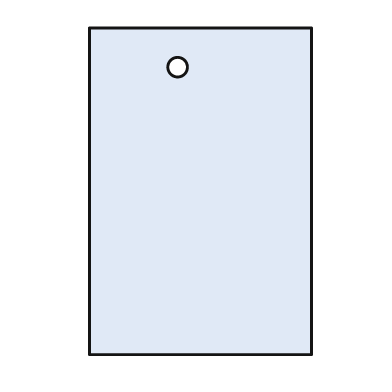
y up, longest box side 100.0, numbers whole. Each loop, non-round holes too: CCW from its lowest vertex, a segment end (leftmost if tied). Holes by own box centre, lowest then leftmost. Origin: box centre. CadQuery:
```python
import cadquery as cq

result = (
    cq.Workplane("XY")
    .moveTo(-34.0, -50.0)
    .lineTo(34.0, -50.0)
    .lineTo(34.0, 50.0)
    .lineTo(-34.0, 50.0)
    .close()
    .moveTo(-7.0, 38.0)
    .circle(3.0)
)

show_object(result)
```